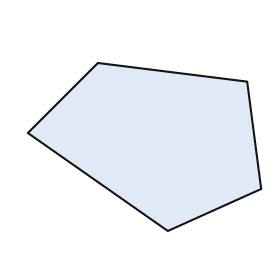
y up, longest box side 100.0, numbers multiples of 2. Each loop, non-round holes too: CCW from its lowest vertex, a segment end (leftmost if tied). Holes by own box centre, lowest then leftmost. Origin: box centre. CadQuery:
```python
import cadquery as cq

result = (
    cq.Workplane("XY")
    .moveTo(10.0, -36.0)
    .lineTo(50.0, -18.0)
    .lineTo(44.0, 28.0)
    .lineTo(-20.0, 36.0)
    .lineTo(-50.0, 6.0)
    .close()
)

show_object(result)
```